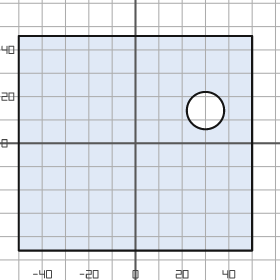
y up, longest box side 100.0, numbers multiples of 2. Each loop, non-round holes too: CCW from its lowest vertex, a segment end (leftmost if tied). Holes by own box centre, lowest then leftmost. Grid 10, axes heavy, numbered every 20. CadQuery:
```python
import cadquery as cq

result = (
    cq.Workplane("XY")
    .moveTo(-50.0, -46.0)
    .lineTo(50.0, -46.0)
    .lineTo(50.0, 46.0)
    .lineTo(-50.0, 46.0)
    .close()
    .moveTo(30.0, 14.0)
    .circle(8.0)
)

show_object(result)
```